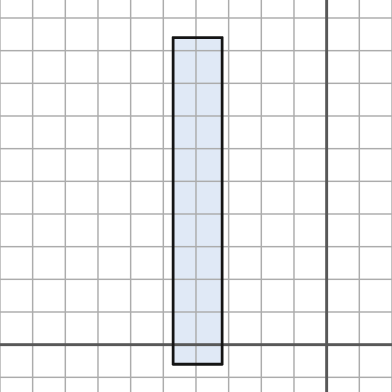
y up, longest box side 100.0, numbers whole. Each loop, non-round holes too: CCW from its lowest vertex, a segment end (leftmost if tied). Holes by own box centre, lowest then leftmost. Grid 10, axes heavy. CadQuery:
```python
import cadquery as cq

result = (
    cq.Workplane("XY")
    .moveTo(-47.0, -6.0)
    .lineTo(-32.0, -6.0)
    .lineTo(-32.0, 94.0)
    .lineTo(-47.0, 94.0)
    .close()
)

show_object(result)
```